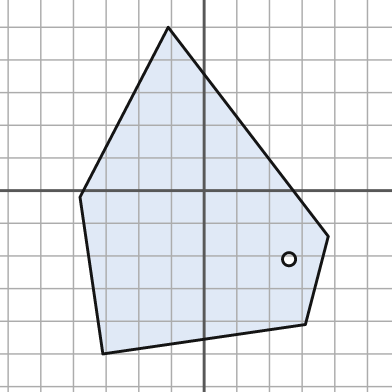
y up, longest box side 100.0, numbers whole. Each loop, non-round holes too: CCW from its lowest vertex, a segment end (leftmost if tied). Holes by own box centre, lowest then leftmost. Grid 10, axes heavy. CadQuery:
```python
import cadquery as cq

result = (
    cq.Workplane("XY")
    .moveTo(-31.0, -50.0)
    .lineTo(31.0, -41.0)
    .lineTo(38.0, -14.0)
    .lineTo(-11.0, 50.0)
    .lineTo(-38.0, -2.0)
    .close()
    .moveTo(26.0, -21.0)
    .circle(2.0)
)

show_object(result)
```